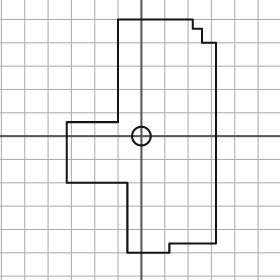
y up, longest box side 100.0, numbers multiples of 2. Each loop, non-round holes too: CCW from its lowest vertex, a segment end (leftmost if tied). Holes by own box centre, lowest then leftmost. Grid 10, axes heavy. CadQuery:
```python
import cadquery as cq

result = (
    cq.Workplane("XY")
    .moveTo(-6.0, -50.0)
    .lineTo(12.0, -50.0)
    .lineTo(12.0, -46.0)
    .lineTo(32.0, -46.0)
    .lineTo(32.0, 40.0)
    .lineTo(26.0, 40.0)
    .lineTo(26.0, 46.0)
    .lineTo(22.0, 46.0)
    .lineTo(22.0, 50.0)
    .lineTo(-10.0, 50.0)
    .lineTo(-10.0, 6.0)
    .lineTo(-32.0, 6.0)
    .lineTo(-32.0, -20.0)
    .lineTo(-6.0, -20.0)
    .close()
    .moveTo(0.0, 0.0)
    .circle(4.0)
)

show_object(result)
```